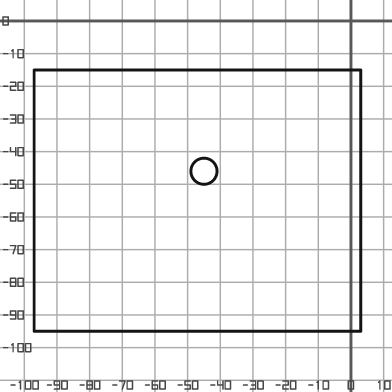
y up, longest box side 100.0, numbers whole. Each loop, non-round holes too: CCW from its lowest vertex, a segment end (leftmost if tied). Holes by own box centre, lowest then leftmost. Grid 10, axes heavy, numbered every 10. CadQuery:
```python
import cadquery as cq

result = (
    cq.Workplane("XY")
    .moveTo(-97.0, -95.0)
    .lineTo(3.0, -95.0)
    .lineTo(3.0, -15.0)
    .lineTo(-97.0, -15.0)
    .close()
    .moveTo(-45.0, -46.0)
    .circle(4.0)
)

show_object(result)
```